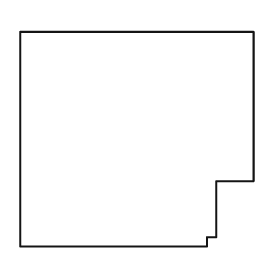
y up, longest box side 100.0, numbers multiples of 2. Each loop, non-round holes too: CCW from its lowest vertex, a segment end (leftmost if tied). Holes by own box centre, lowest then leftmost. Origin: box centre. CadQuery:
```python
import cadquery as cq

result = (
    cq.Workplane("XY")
    .moveTo(-50.0, -46.0)
    .lineTo(30.0, -46.0)
    .lineTo(30.0, -42.0)
    .lineTo(34.0, -42.0)
    .lineTo(34.0, -18.0)
    .lineTo(50.0, -18.0)
    .lineTo(50.0, 46.0)
    .lineTo(-50.0, 46.0)
    .close()
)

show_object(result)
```